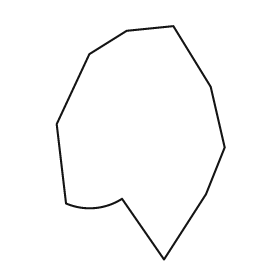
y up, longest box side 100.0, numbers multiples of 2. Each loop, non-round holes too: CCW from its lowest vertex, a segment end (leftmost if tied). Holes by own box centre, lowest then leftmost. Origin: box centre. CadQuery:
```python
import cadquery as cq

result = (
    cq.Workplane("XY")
    .moveTo(10.0, -50.0)
    .lineTo(28.0, -22.0)
    .lineTo(36.0, -2.0)
    .lineTo(30.0, 24.0)
    .lineTo(14.0, 50.0)
    .lineTo(-6.0, 48.0)
    .lineTo(-22.0, 38.0)
    .lineTo(-36.0, 8.0)
    .lineTo(-32.0, -26.0)
    .threePointArc((-20.0, -28.0), (-8.0, -24.0))
    .close()
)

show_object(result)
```